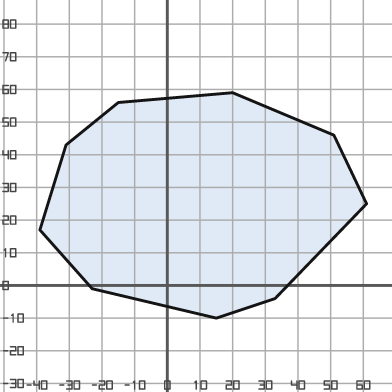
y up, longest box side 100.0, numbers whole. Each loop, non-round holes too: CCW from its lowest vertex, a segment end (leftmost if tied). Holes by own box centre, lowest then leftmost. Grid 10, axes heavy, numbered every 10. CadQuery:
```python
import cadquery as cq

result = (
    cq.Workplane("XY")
    .moveTo(15.0, -10.0)
    .lineTo(33.0, -4.0)
    .lineTo(61.0, 25.0)
    .lineTo(51.0, 46.0)
    .lineTo(20.0, 59.0)
    .lineTo(-15.0, 56.0)
    .lineTo(-31.0, 43.0)
    .lineTo(-39.0, 17.0)
    .lineTo(-23.0, -1.0)
    .close()
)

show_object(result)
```